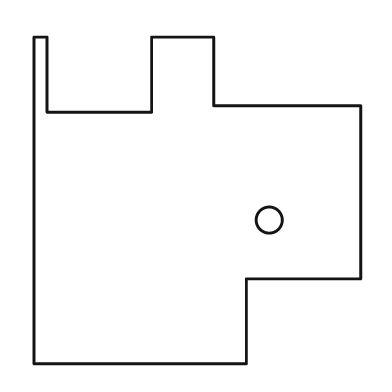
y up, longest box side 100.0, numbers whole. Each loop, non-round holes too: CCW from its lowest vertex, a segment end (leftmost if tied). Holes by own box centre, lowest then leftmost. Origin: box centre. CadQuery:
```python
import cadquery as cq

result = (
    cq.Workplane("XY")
    .moveTo(-50.0, -50.0)
    .lineTo(15.0, -50.0)
    .lineTo(15.0, -24.0)
    .lineTo(50.0, -24.0)
    .lineTo(50.0, 29.0)
    .lineTo(5.0, 29.0)
    .lineTo(5.0, 50.0)
    .lineTo(-14.0, 50.0)
    .lineTo(-14.0, 27.0)
    .lineTo(-46.0, 27.0)
    .lineTo(-46.0, 50.0)
    .lineTo(-50.0, 50.0)
    .close()
    .moveTo(22.0, -6.0)
    .circle(4.0)
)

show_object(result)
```